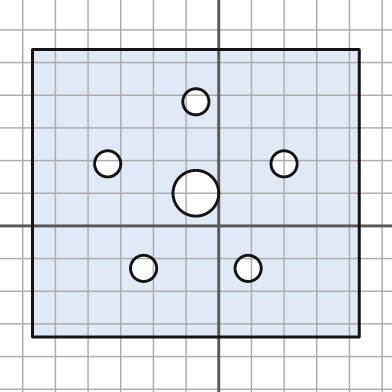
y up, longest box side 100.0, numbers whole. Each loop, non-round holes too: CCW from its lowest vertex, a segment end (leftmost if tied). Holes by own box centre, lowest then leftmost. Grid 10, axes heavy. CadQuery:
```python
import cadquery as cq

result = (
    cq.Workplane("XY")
    .moveTo(-57.0, -34.0)
    .lineTo(43.0, -34.0)
    .lineTo(43.0, 54.0)
    .lineTo(-57.0, 54.0)
    .close()
    .moveTo(-23.0, -13.0)
    .circle(4.0)
    .moveTo(9.0, -13.0)
    .circle(4.0)
    .moveTo(-7.0, 10.0)
    .circle(7.0)
    .moveTo(-34.0, 19.0)
    .circle(4.0)
    .moveTo(20.0, 19.0)
    .circle(4.0)
    .moveTo(-7.0, 38.0)
    .circle(4.0)
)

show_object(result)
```